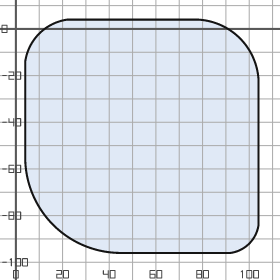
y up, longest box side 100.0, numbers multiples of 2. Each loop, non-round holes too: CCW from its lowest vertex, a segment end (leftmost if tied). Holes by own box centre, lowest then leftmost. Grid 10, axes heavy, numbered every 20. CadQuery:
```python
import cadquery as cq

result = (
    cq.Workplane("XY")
    .moveTo(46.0, -96.0)
    .lineTo(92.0, -96.0)
    .threePointArc((100.0, -92.0), (104.0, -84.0))
    .lineTo(104.0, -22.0)
    .threePointArc((96.0, -4.0), (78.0, 4.0))
    .lineTo(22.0, 4.0)
    .threePointArc((10.0, -2.0), (4.0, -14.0))
    .lineTo(4.0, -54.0)
    .threePointArc((16.0, -84.0), (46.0, -96.0))
    .close()
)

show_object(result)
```